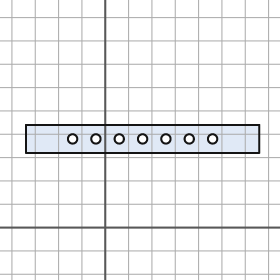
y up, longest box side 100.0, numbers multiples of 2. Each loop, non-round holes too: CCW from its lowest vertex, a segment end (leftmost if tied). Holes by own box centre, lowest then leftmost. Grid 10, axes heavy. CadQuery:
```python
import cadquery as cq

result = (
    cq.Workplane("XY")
    .moveTo(-34.0, 32.0)
    .lineTo(66.0, 32.0)
    .lineTo(66.0, 44.0)
    .lineTo(-34.0, 44.0)
    .close()
    .moveTo(-14.0, 38.0)
    .circle(2.0)
    .moveTo(-4.0, 38.0)
    .circle(2.0)
    .moveTo(6.0, 38.0)
    .circle(2.0)
    .moveTo(16.0, 38.0)
    .circle(2.0)
    .moveTo(26.0, 38.0)
    .circle(2.0)
    .moveTo(36.0, 38.0)
    .circle(2.0)
    .moveTo(46.0, 38.0)
    .circle(2.0)
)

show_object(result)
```